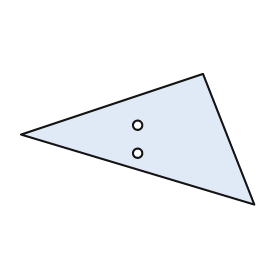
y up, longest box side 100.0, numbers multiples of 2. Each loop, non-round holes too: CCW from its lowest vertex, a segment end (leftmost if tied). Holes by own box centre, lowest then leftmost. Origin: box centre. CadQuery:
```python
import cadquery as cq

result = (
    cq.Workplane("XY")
    .moveTo(50.0, -28.0)
    .lineTo(28.0, 28.0)
    .lineTo(-50.0, 2.0)
    .close()
    .moveTo(0.0, -6.0)
    .circle(2.0)
    .moveTo(0.0, 6.0)
    .circle(2.0)
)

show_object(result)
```